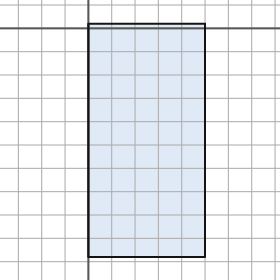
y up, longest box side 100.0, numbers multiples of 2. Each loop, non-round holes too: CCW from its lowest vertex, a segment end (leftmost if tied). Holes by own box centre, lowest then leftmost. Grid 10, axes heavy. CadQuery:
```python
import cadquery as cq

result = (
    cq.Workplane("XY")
    .moveTo(0.0, -98.0)
    .lineTo(50.0, -98.0)
    .lineTo(50.0, 2.0)
    .lineTo(0.0, 2.0)
    .close()
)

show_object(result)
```